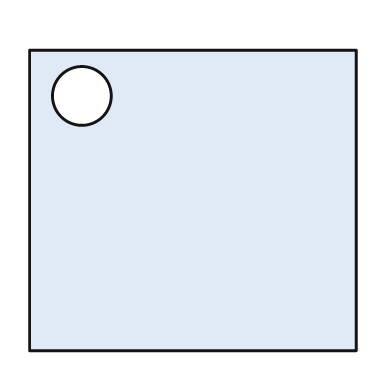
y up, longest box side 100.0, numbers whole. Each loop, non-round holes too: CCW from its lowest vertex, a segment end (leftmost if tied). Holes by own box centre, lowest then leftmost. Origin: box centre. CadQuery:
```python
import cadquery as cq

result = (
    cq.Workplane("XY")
    .moveTo(-50.0, -46.0)
    .lineTo(50.0, -46.0)
    .lineTo(50.0, 46.0)
    .lineTo(-50.0, 46.0)
    .close()
    .moveTo(-34.0, 32.0)
    .circle(9.0)
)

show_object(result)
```